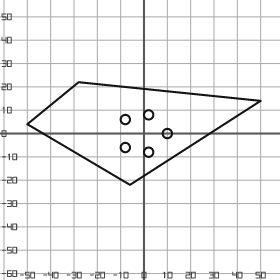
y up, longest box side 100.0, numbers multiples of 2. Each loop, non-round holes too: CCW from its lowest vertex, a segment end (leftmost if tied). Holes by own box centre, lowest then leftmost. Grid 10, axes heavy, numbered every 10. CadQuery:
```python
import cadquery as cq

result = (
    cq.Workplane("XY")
    .moveTo(-6.0, -22.0)
    .lineTo(50.0, 14.0)
    .lineTo(-28.0, 22.0)
    .lineTo(-50.0, 4.0)
    .close()
    .moveTo(2.0, -8.0)
    .circle(2.0)
    .moveTo(-8.0, -6.0)
    .circle(2.0)
    .moveTo(10.0, 0.0)
    .circle(2.0)
    .moveTo(-8.0, 6.0)
    .circle(2.0)
    .moveTo(2.0, 8.0)
    .circle(2.0)
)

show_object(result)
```